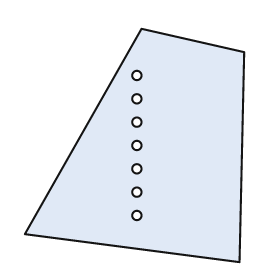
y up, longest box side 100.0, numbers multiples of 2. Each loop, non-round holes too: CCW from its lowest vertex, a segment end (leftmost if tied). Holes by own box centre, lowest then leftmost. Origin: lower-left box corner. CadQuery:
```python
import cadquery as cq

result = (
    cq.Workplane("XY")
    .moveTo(92.0, 0.0)
    .lineTo(94.0, 90.0)
    .lineTo(50.0, 100.0)
    .lineTo(0.0, 12.0)
    .close()
    .moveTo(48.0, 20.0)
    .circle(2.0)
    .moveTo(48.0, 30.0)
    .circle(2.0)
    .moveTo(48.0, 40.0)
    .circle(2.0)
    .moveTo(48.0, 50.0)
    .circle(2.0)
    .moveTo(48.0, 60.0)
    .circle(2.0)
    .moveTo(48.0, 70.0)
    .circle(2.0)
    .moveTo(48.0, 80.0)
    .circle(2.0)
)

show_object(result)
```